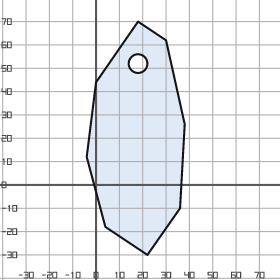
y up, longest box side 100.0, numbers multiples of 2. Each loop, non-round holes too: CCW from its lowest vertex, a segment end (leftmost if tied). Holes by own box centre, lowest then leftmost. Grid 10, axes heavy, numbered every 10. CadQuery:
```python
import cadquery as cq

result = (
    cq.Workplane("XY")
    .moveTo(22.0, -30.0)
    .lineTo(36.0, -10.0)
    .lineTo(38.0, 26.0)
    .lineTo(30.0, 62.0)
    .lineTo(18.0, 70.0)
    .lineTo(0.0, 44.0)
    .lineTo(-4.0, 12.0)
    .lineTo(4.0, -18.0)
    .close()
    .moveTo(18.0, 52.0)
    .circle(4.0)
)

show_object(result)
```